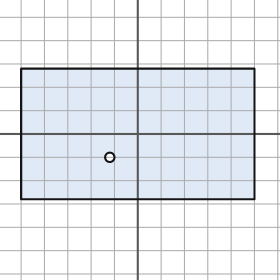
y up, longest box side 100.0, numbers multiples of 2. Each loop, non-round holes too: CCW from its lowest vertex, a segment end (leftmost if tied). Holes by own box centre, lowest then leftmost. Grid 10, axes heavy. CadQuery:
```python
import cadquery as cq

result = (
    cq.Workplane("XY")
    .moveTo(-50.0, -28.0)
    .lineTo(50.0, -28.0)
    .lineTo(50.0, 28.0)
    .lineTo(-50.0, 28.0)
    .close()
    .moveTo(-12.0, -10.0)
    .circle(2.0)
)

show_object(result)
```